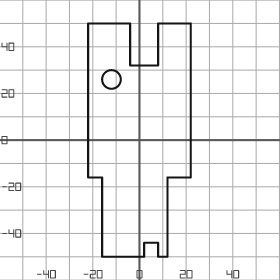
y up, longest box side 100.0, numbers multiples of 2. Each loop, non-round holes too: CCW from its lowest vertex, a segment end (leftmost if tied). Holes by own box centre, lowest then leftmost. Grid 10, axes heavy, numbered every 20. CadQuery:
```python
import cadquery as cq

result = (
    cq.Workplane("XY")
    .moveTo(-16.0, -50.0)
    .lineTo(2.0, -50.0)
    .lineTo(2.0, -44.0)
    .lineTo(8.0, -44.0)
    .lineTo(8.0, -50.0)
    .lineTo(12.0, -50.0)
    .lineTo(12.0, -16.0)
    .lineTo(22.0, -16.0)
    .lineTo(22.0, 50.0)
    .lineTo(8.0, 50.0)
    .lineTo(8.0, 32.0)
    .lineTo(-4.0, 32.0)
    .lineTo(-4.0, 50.0)
    .lineTo(-22.0, 50.0)
    .lineTo(-22.0, -16.0)
    .lineTo(-16.0, -16.0)
    .close()
    .moveTo(-12.0, 26.0)
    .circle(4.0)
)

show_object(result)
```